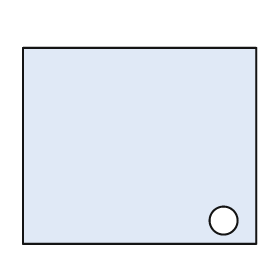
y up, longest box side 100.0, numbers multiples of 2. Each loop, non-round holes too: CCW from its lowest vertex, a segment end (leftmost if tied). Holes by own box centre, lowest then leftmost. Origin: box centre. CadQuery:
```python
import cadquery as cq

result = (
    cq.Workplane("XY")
    .moveTo(-50.0, -42.0)
    .lineTo(50.0, -42.0)
    .lineTo(50.0, 42.0)
    .lineTo(-50.0, 42.0)
    .close()
    .moveTo(36.0, -32.0)
    .circle(6.0)
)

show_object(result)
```